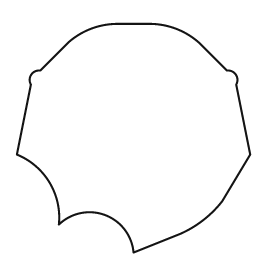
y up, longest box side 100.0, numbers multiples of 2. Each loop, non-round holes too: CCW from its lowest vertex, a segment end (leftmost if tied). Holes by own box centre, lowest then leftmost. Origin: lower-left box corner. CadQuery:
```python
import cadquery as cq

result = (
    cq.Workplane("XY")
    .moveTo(50.0, 0.0)
    .lineTo(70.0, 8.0)
    .threePointArc((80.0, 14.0), (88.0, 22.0))
    .lineTo(100.0, 42.0)
    .lineTo(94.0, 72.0)
    .threePointArc((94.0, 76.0), (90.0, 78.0))
    .lineTo(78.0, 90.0)
    .threePointArc((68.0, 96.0), (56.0, 98.0))
    .lineTo(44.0, 98.0)
    .threePointArc((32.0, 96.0), (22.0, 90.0))
    .lineTo(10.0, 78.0)
    .threePointArc((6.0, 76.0), (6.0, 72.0))
    .lineTo(0.0, 42.0)
    .threePointArc((14.0, 30.0), (18.0, 12.0))
    .threePointArc((38.0, 16.0), (50.0, 0.0))
    .close()
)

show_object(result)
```